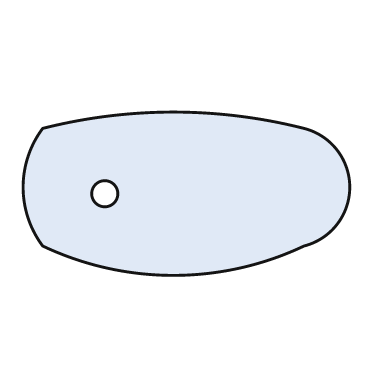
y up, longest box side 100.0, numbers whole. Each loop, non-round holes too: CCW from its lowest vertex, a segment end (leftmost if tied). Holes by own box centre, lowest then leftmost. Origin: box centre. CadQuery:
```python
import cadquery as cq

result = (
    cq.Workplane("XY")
    .moveTo(-44.0, -16.0)
    .threePointArc((-4.0, -25.0), (36.0, -16.0))
    .threePointArc((50.0, 2.0), (36.0, 20.0))
    .threePointArc((-4.0, 25.0), (-44.0, 20.0))
    .threePointArc((-50.0, 2.0), (-44.0, -16.0))
    .close()
    .moveTo(-25.0, 0.0)
    .circle(4.0)
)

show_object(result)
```